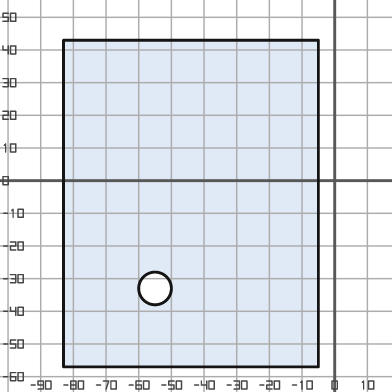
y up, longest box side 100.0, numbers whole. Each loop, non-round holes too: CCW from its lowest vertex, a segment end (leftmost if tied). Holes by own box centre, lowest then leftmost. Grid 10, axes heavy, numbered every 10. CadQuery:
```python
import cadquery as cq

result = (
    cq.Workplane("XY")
    .moveTo(-83.0, -57.0)
    .lineTo(-5.0, -57.0)
    .lineTo(-5.0, 43.0)
    .lineTo(-83.0, 43.0)
    .close()
    .moveTo(-55.0, -33.0)
    .circle(5.0)
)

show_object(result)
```